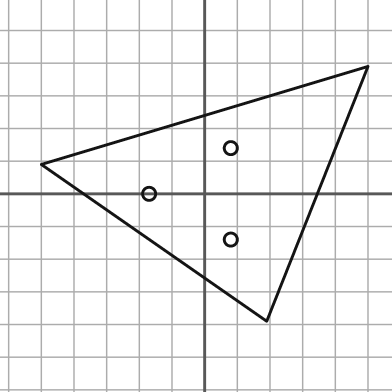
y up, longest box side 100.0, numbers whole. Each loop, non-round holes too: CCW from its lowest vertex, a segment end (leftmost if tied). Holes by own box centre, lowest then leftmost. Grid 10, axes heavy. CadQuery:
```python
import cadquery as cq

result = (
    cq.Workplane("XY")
    .moveTo(19.0, -39.0)
    .lineTo(50.0, 39.0)
    .lineTo(-50.0, 9.0)
    .close()
    .moveTo(8.0, -14.0)
    .circle(2.0)
    .moveTo(-17.0, 0.0)
    .circle(2.0)
    .moveTo(8.0, 14.0)
    .circle(2.0)
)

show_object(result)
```